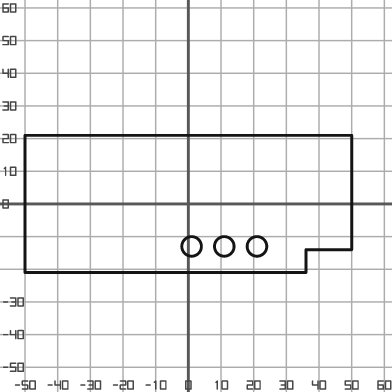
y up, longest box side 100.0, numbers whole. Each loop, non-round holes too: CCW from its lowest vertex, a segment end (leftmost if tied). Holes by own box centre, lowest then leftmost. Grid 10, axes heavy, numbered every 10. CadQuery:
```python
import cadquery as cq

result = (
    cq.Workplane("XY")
    .moveTo(-50.0, -21.0)
    .lineTo(36.0, -21.0)
    .lineTo(36.0, -14.0)
    .lineTo(50.0, -14.0)
    .lineTo(50.0, 21.0)
    .lineTo(-50.0, 21.0)
    .close()
    .moveTo(1.0, -13.0)
    .circle(3.0)
    .moveTo(11.0, -13.0)
    .circle(3.0)
    .moveTo(21.0, -13.0)
    .circle(3.0)
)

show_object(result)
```